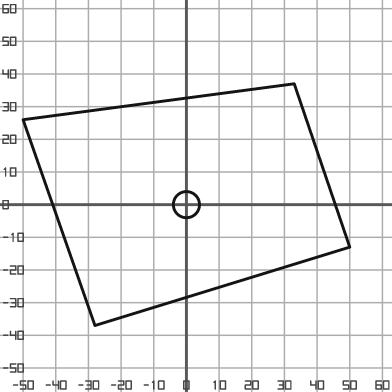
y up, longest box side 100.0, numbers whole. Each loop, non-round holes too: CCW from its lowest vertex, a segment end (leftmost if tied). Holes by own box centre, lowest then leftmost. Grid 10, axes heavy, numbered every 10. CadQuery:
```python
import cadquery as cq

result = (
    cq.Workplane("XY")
    .moveTo(-28.0, -37.0)
    .lineTo(50.0, -13.0)
    .lineTo(33.0, 37.0)
    .lineTo(-50.0, 26.0)
    .close()
    .moveTo(0.0, 0.0)
    .circle(4.0)
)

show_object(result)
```